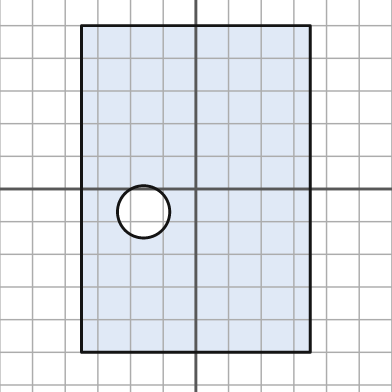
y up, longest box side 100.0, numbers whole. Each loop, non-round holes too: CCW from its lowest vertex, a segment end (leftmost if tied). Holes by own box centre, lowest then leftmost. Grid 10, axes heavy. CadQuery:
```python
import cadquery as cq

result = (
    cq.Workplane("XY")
    .moveTo(-35.0, -50.0)
    .lineTo(35.0, -50.0)
    .lineTo(35.0, 50.0)
    .lineTo(-35.0, 50.0)
    .close()
    .moveTo(-16.0, -7.0)
    .circle(8.0)
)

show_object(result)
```